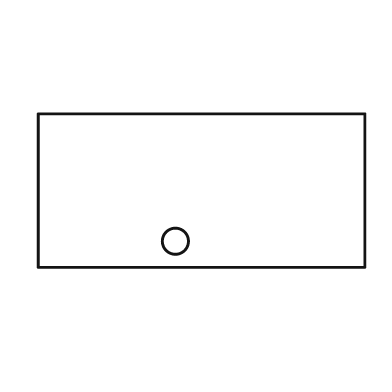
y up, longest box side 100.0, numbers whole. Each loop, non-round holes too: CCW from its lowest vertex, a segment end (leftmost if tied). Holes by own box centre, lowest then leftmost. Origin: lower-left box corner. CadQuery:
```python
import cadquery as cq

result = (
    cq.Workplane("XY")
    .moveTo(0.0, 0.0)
    .lineTo(100.0, 0.0)
    .lineTo(100.0, 47.0)
    .lineTo(0.0, 47.0)
    .close()
    .moveTo(42.0, 8.0)
    .circle(4.0)
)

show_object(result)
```